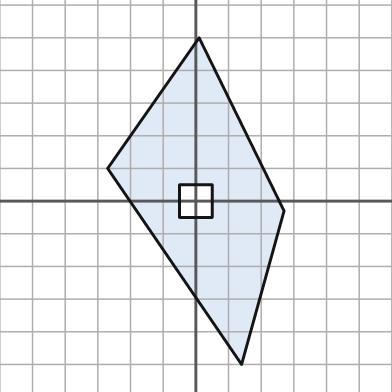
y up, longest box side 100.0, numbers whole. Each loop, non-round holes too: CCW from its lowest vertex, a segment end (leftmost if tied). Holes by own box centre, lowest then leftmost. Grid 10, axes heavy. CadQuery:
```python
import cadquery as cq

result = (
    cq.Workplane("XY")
    .moveTo(14.0, -50.0)
    .lineTo(27.0, -3.0)
    .lineTo(1.0, 50.0)
    .lineTo(-27.0, 10.0)
    .close()
    .moveTo(-5.0, -5.0)
    .lineTo(5.0, -5.0)
    .lineTo(5.0, 5.0)
    .lineTo(-5.0, 5.0)
    .close()
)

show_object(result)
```